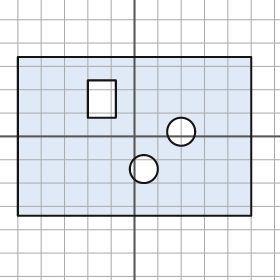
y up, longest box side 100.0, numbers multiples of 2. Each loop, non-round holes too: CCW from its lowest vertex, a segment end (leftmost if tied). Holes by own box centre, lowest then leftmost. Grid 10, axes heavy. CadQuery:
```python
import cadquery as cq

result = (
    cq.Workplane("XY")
    .moveTo(-50.0, -34.0)
    .lineTo(50.0, -34.0)
    .lineTo(50.0, 34.0)
    .lineTo(-50.0, 34.0)
    .close()
    .moveTo(4.0, -14.0)
    .circle(6.0)
    .moveTo(20.0, 2.0)
    .circle(6.0)
    .moveTo(-20.0, 8.0)
    .lineTo(-8.0, 8.0)
    .lineTo(-8.0, 24.0)
    .lineTo(-20.0, 24.0)
    .close()
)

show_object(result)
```